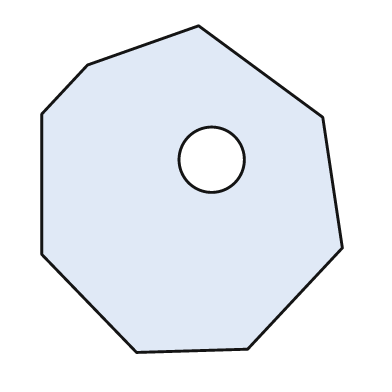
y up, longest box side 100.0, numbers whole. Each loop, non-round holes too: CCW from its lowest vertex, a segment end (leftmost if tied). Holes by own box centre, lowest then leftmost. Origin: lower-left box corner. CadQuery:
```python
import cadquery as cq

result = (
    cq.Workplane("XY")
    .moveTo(29.0, 0.0)
    .lineTo(63.0, 1.0)
    .lineTo(92.0, 32.0)
    .lineTo(86.0, 72.0)
    .lineTo(48.0, 100.0)
    .lineTo(14.0, 88.0)
    .lineTo(0.0, 73.0)
    .lineTo(0.0, 30.0)
    .close()
    .moveTo(52.0, 59.0)
    .circle(10.0)
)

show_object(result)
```